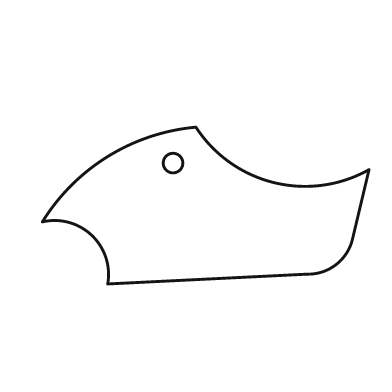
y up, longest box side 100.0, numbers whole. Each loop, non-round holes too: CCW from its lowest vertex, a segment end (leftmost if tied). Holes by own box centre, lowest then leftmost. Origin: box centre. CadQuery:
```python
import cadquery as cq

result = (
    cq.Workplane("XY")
    .moveTo(-30.0, -24.0)
    .lineTo(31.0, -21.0)
    .threePointArc((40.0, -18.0), (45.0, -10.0))
    .lineTo(50.0, 11.0)
    .threePointArc((21.0, 7.0), (-3.0, 24.0))
    .threePointArc((-30.0, 15.0), (-50.0, -5.0))
    .threePointArc((-35.0, -9.0), (-30.0, -24.0))
    .close()
    .moveTo(-10.0, 13.0)
    .circle(3.0)
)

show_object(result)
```